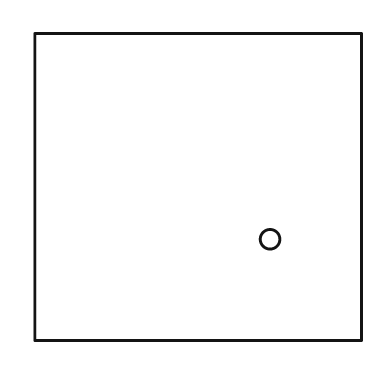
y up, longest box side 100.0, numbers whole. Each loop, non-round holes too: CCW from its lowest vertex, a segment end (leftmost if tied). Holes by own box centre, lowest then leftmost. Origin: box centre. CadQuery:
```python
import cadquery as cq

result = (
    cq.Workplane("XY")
    .moveTo(-50.0, -47.0)
    .lineTo(50.0, -47.0)
    .lineTo(50.0, 47.0)
    .lineTo(-50.0, 47.0)
    .close()
    .moveTo(22.0, -16.0)
    .circle(3.0)
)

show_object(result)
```